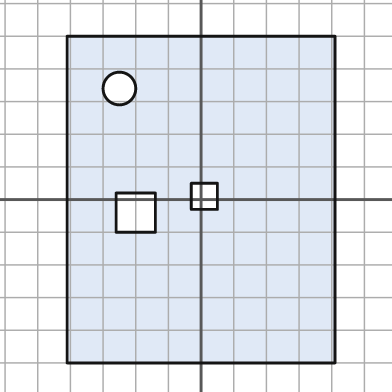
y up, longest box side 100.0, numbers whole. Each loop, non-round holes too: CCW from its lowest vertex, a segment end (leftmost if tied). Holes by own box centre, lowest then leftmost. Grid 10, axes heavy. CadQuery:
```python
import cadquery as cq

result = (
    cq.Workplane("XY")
    .moveTo(-41.0, -50.0)
    .lineTo(41.0, -50.0)
    .lineTo(41.0, 50.0)
    .lineTo(-41.0, 50.0)
    .close()
    .moveTo(-26.0, -10.0)
    .lineTo(-14.0, -10.0)
    .lineTo(-14.0, 2.0)
    .lineTo(-26.0, 2.0)
    .close()
    .moveTo(-3.0, -3.0)
    .lineTo(5.0, -3.0)
    .lineTo(5.0, 5.0)
    .lineTo(-3.0, 5.0)
    .close()
    .moveTo(-25.0, 34.0)
    .circle(5.0)
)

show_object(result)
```